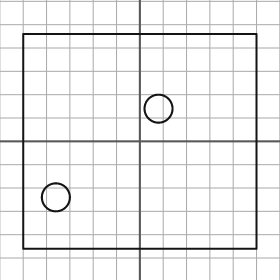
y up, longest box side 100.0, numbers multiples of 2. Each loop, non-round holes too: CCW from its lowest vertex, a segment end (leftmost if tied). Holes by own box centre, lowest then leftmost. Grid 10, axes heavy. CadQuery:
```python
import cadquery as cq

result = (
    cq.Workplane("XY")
    .moveTo(-50.0, -46.0)
    .lineTo(50.0, -46.0)
    .lineTo(50.0, 46.0)
    .lineTo(-50.0, 46.0)
    .close()
    .moveTo(-36.0, -24.0)
    .circle(6.0)
    .moveTo(8.0, 14.0)
    .circle(6.0)
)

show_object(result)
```